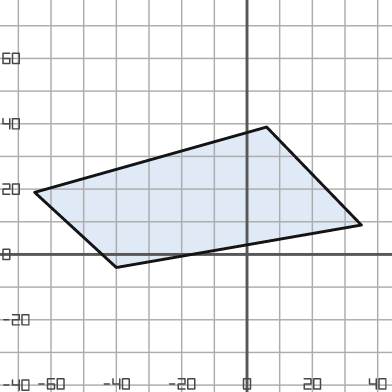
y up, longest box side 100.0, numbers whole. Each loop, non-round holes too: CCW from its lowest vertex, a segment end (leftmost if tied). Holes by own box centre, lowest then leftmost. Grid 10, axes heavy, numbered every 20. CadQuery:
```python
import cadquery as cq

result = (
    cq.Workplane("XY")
    .moveTo(-40.0, -4.0)
    .lineTo(35.0, 9.0)
    .lineTo(6.0, 39.0)
    .lineTo(-65.0, 19.0)
    .close()
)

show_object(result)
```